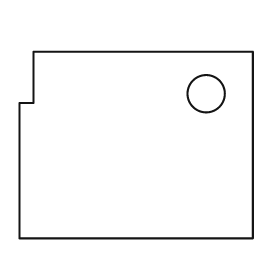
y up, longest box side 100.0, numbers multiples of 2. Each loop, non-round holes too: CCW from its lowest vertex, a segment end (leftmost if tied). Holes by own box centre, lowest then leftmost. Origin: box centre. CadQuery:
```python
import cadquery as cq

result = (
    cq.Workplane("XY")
    .moveTo(-50.0, -40.0)
    .lineTo(50.0, -40.0)
    .lineTo(50.0, 40.0)
    .lineTo(-44.0, 40.0)
    .lineTo(-44.0, 18.0)
    .lineTo(-50.0, 18.0)
    .close()
    .moveTo(30.0, 22.0)
    .circle(8.0)
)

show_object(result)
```